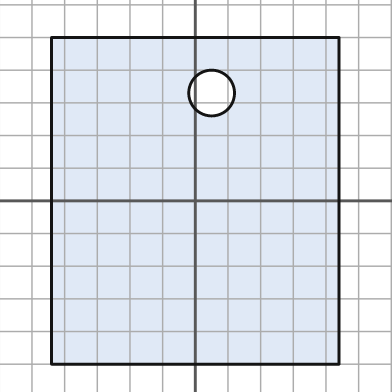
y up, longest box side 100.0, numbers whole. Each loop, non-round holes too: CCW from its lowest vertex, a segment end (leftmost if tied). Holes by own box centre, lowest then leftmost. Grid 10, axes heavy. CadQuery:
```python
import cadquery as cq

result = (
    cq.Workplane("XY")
    .moveTo(-44.0, -50.0)
    .lineTo(44.0, -50.0)
    .lineTo(44.0, 50.0)
    .lineTo(-44.0, 50.0)
    .close()
    .moveTo(5.0, 33.0)
    .circle(7.0)
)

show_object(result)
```